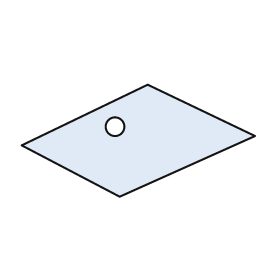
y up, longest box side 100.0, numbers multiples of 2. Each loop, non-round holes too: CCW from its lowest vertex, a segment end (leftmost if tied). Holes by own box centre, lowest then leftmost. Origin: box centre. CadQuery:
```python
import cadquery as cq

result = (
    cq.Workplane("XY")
    .moveTo(-8.0, -24.0)
    .lineTo(50.0, 2.0)
    .lineTo(4.0, 24.0)
    .lineTo(-50.0, -2.0)
    .close()
    .moveTo(-10.0, 6.0)
    .circle(4.0)
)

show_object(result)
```